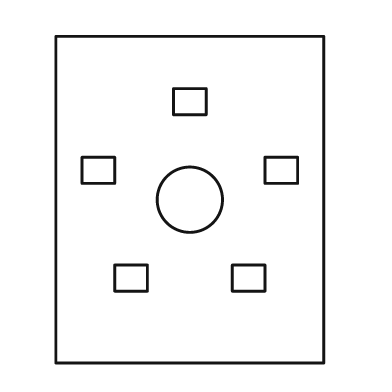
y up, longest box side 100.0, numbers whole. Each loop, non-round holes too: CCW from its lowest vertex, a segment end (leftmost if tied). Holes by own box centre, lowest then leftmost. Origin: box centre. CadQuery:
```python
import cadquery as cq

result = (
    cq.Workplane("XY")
    .moveTo(-41.0, -50.0)
    .lineTo(41.0, -50.0)
    .lineTo(41.0, 50.0)
    .lineTo(-41.0, 50.0)
    .close()
    .moveTo(-23.0, -28.0)
    .lineTo(-13.0, -28.0)
    .lineTo(-13.0, -20.0)
    .lineTo(-23.0, -20.0)
    .close()
    .moveTo(13.0, -28.0)
    .lineTo(23.0, -28.0)
    .lineTo(23.0, -20.0)
    .lineTo(13.0, -20.0)
    .close()
    .moveTo(0.0, 0.0)
    .circle(10.0)
    .moveTo(-33.0, 5.0)
    .lineTo(-23.0, 5.0)
    .lineTo(-23.0, 13.0)
    .lineTo(-33.0, 13.0)
    .close()
    .moveTo(23.0, 5.0)
    .lineTo(33.0, 5.0)
    .lineTo(33.0, 13.0)
    .lineTo(23.0, 13.0)
    .close()
    .moveTo(-5.0, 26.0)
    .lineTo(5.0, 26.0)
    .lineTo(5.0, 34.0)
    .lineTo(-5.0, 34.0)
    .close()
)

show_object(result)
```